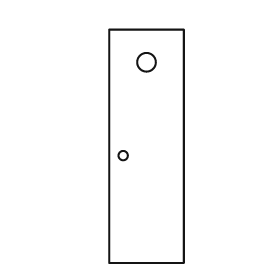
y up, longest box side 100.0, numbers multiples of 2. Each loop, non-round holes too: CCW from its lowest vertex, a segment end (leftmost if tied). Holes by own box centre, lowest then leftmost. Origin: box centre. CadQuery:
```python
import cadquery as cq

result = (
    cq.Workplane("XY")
    .moveTo(-16.0, -50.0)
    .lineTo(16.0, -50.0)
    .lineTo(16.0, 50.0)
    .lineTo(-16.0, 50.0)
    .close()
    .moveTo(-10.0, -4.0)
    .circle(2.0)
    .moveTo(0.0, 36.0)
    .circle(4.0)
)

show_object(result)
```